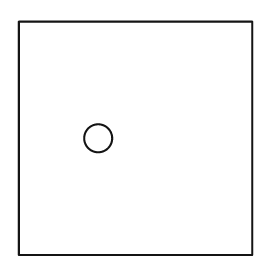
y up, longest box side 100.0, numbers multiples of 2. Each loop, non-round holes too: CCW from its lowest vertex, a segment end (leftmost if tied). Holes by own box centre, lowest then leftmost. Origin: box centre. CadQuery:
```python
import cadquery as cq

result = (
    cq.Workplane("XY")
    .moveTo(-50.0, -50.0)
    .lineTo(50.0, -50.0)
    .lineTo(50.0, 50.0)
    .lineTo(-50.0, 50.0)
    .close()
    .moveTo(-16.0, 0.0)
    .circle(6.0)
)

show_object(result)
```